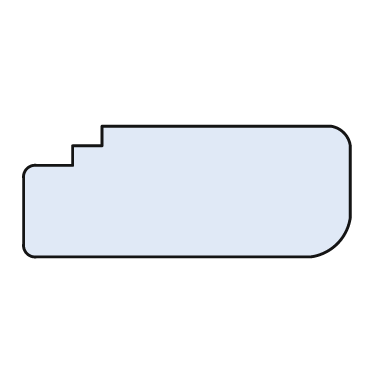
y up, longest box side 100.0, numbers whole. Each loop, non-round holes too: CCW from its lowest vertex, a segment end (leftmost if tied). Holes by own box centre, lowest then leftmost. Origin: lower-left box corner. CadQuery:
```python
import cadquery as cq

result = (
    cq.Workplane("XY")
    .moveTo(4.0, 0.0)
    .lineTo(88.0, 0.0)
    .threePointArc((96.0, 4.0), (100.0, 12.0))
    .lineTo(100.0, 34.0)
    .threePointArc((98.0, 38.0), (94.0, 40.0))
    .lineTo(24.0, 40.0)
    .lineTo(24.0, 34.0)
    .lineTo(15.0, 34.0)
    .lineTo(15.0, 28.0)
    .lineTo(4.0, 28.0)
    .threePointArc((1.0, 27.0), (0.0, 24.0))
    .lineTo(0.0, 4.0)
    .threePointArc((1.0, 1.0), (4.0, 0.0))
    .close()
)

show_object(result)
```